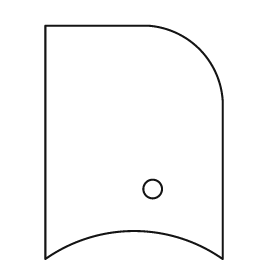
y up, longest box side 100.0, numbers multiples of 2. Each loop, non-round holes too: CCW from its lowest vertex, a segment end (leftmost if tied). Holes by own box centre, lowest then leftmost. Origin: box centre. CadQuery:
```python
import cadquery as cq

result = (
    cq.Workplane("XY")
    .moveTo(-38.0, -50.0)
    .threePointArc((0.0, -38.0), (38.0, -50.0))
    .lineTo(38.0, 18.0)
    .threePointArc((28.0, 40.0), (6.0, 50.0))
    .lineTo(-38.0, 50.0)
    .close()
    .moveTo(8.0, -20.0)
    .circle(4.0)
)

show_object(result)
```